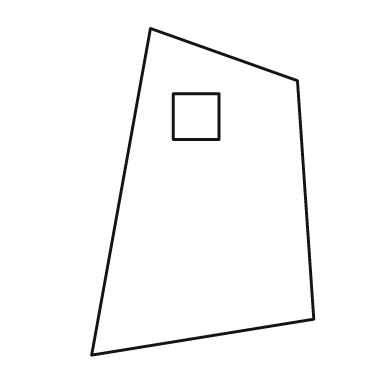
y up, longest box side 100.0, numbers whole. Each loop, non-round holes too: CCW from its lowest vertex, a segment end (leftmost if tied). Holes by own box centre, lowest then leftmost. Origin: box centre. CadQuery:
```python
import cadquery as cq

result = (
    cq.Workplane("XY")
    .moveTo(-34.0, -50.0)
    .lineTo(34.0, -39.0)
    .lineTo(29.0, 34.0)
    .lineTo(-16.0, 50.0)
    .close()
    .moveTo(-9.0, 16.0)
    .lineTo(5.0, 16.0)
    .lineTo(5.0, 30.0)
    .lineTo(-9.0, 30.0)
    .close()
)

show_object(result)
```